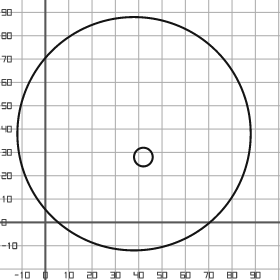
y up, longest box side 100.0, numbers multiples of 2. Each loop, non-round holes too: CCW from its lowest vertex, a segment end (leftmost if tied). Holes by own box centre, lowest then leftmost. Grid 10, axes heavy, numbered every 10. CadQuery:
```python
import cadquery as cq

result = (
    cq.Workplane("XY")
    .moveTo(38.0, 38.0)
    .circle(50.0)
    .moveTo(42.0, 28.0)
    .circle(4.0)
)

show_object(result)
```